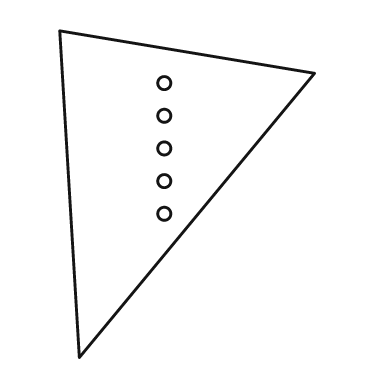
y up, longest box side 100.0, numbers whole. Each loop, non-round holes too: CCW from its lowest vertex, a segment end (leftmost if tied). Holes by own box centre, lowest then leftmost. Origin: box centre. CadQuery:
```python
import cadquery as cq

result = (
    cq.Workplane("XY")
    .moveTo(-33.0, -50.0)
    .lineTo(39.0, 37.0)
    .lineTo(-39.0, 50.0)
    .close()
    .moveTo(-7.0, -6.0)
    .circle(2.0)
    .moveTo(-7.0, 4.0)
    .circle(2.0)
    .moveTo(-7.0, 14.0)
    .circle(2.0)
    .moveTo(-7.0, 24.0)
    .circle(2.0)
    .moveTo(-7.0, 34.0)
    .circle(2.0)
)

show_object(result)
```